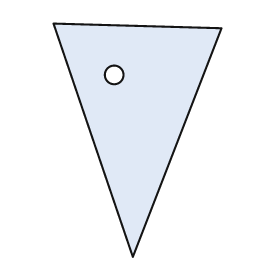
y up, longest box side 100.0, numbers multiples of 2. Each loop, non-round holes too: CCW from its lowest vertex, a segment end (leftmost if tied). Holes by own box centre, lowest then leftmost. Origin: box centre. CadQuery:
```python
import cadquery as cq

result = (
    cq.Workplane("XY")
    .moveTo(-2.0, -50.0)
    .lineTo(36.0, 48.0)
    .lineTo(-36.0, 50.0)
    .close()
    .moveTo(-10.0, 28.0)
    .circle(4.0)
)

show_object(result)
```